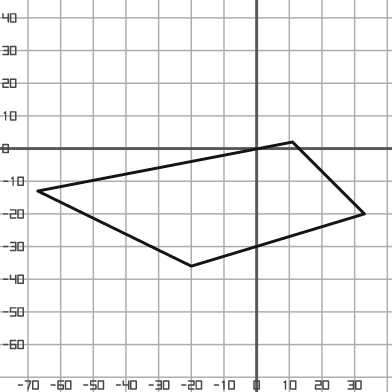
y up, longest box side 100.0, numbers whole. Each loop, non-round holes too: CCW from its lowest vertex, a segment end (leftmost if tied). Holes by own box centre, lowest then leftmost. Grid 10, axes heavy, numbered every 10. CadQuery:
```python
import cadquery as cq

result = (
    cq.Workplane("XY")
    .moveTo(-20.0, -36.0)
    .lineTo(33.0, -20.0)
    .lineTo(11.0, 2.0)
    .lineTo(-67.0, -13.0)
    .close()
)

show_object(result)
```